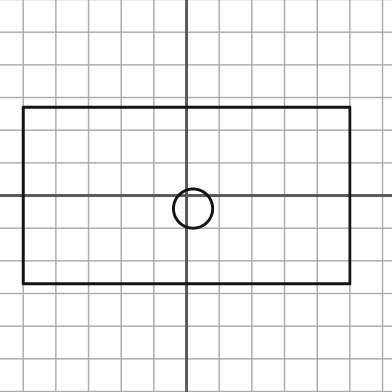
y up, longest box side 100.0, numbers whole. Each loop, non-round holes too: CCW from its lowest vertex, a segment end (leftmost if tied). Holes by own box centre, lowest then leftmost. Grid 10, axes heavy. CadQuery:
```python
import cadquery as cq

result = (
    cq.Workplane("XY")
    .moveTo(-50.0, -27.0)
    .lineTo(50.0, -27.0)
    .lineTo(50.0, 27.0)
    .lineTo(-50.0, 27.0)
    .close()
    .moveTo(2.0, -4.0)
    .circle(6.0)
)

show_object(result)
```